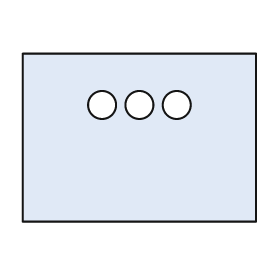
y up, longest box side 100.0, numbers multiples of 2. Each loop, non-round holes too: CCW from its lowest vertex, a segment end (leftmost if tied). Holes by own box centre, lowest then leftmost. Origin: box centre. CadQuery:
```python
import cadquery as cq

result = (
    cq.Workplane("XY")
    .moveTo(-50.0, -36.0)
    .lineTo(50.0, -36.0)
    .lineTo(50.0, 36.0)
    .lineTo(-50.0, 36.0)
    .close()
    .moveTo(-16.0, 14.0)
    .circle(6.0)
    .moveTo(0.0, 14.0)
    .circle(6.0)
    .moveTo(16.0, 14.0)
    .circle(6.0)
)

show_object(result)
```